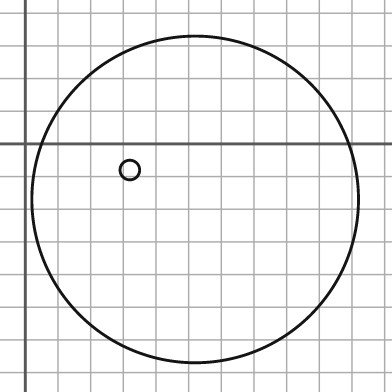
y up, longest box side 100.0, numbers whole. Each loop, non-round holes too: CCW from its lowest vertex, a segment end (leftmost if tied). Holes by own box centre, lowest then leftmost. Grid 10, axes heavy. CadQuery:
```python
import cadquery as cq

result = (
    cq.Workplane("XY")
    .moveTo(52.0, -17.0)
    .circle(50.0)
    .moveTo(32.0, -8.0)
    .circle(3.0)
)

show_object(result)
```